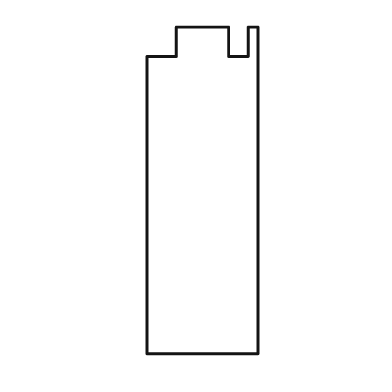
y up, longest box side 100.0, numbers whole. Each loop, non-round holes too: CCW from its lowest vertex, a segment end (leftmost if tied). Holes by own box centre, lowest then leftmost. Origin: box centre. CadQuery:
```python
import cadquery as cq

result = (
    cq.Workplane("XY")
    .moveTo(-17.0, -50.0)
    .lineTo(17.0, -50.0)
    .lineTo(17.0, 50.0)
    .lineTo(14.0, 50.0)
    .lineTo(14.0, 41.0)
    .lineTo(8.0, 41.0)
    .lineTo(8.0, 50.0)
    .lineTo(-8.0, 50.0)
    .lineTo(-8.0, 41.0)
    .lineTo(-17.0, 41.0)
    .close()
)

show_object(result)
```